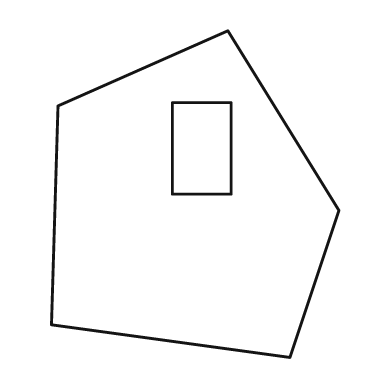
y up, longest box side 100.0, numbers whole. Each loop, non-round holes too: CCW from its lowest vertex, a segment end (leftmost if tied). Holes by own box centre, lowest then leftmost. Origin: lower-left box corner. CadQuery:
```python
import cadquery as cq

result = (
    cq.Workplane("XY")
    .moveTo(73.0, 0.0)
    .lineTo(88.0, 45.0)
    .lineTo(54.0, 100.0)
    .lineTo(2.0, 77.0)
    .lineTo(0.0, 10.0)
    .close()
    .moveTo(37.0, 50.0)
    .lineTo(55.0, 50.0)
    .lineTo(55.0, 78.0)
    .lineTo(37.0, 78.0)
    .close()
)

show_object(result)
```